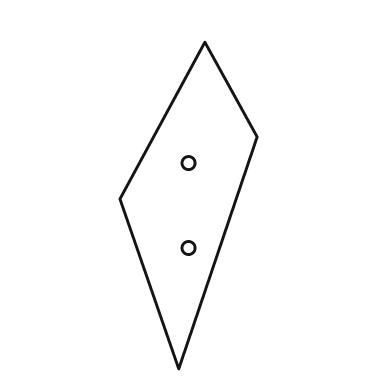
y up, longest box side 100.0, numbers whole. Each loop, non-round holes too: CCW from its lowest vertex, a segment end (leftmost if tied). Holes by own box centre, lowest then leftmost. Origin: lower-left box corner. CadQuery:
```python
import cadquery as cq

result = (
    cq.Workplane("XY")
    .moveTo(18.0, 0.0)
    .lineTo(42.0, 71.0)
    .lineTo(26.0, 100.0)
    .lineTo(0.0, 52.0)
    .close()
    .moveTo(21.0, 37.0)
    .circle(2.0)
    .moveTo(21.0, 63.0)
    .circle(2.0)
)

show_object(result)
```